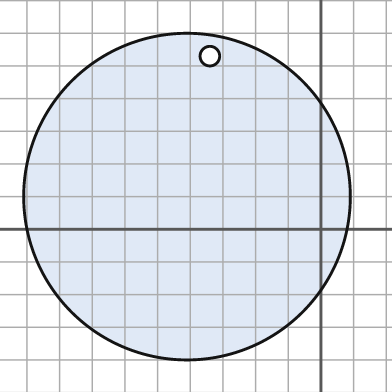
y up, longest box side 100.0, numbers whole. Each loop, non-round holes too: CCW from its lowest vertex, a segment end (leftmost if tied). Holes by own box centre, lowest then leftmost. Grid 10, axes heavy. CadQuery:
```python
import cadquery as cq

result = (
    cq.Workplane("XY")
    .moveTo(-41.0, 10.0)
    .circle(50.0)
    .moveTo(-34.0, 53.0)
    .circle(3.0)
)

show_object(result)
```